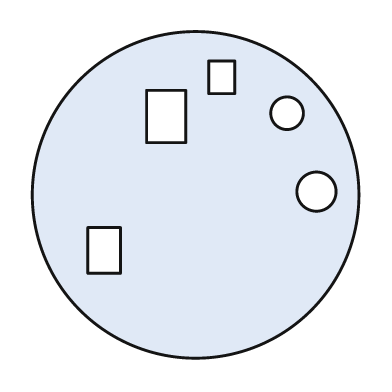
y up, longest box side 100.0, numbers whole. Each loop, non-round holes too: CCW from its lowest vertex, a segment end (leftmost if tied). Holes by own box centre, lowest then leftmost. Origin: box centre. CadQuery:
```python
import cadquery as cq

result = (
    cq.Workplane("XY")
    .moveTo(0.0, 0.0)
    .circle(50.0)
    .moveTo(-33.0, -24.0)
    .lineTo(-23.0, -24.0)
    .lineTo(-23.0, -10.0)
    .lineTo(-33.0, -10.0)
    .close()
    .moveTo(37.0, 1.0)
    .circle(6.0)
    .moveTo(-15.0, 16.0)
    .lineTo(-3.0, 16.0)
    .lineTo(-3.0, 32.0)
    .lineTo(-15.0, 32.0)
    .close()
    .moveTo(28.0, 25.0)
    .circle(5.0)
    .moveTo(4.0, 31.0)
    .lineTo(12.0, 31.0)
    .lineTo(12.0, 41.0)
    .lineTo(4.0, 41.0)
    .close()
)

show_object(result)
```